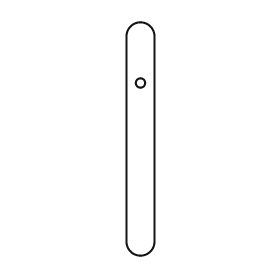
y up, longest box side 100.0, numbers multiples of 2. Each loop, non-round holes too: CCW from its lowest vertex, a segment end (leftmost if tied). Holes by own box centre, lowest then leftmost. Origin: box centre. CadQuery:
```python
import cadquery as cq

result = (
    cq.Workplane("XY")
    .moveTo(-6.0, -44.0)
    .threePointArc((0.0, -50.0), (6.0, -44.0))
    .lineTo(6.0, 44.0)
    .threePointArc((0.0, 50.0), (-6.0, 44.0))
    .close()
    .moveTo(0.0, 24.0)
    .circle(2.0)
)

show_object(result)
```